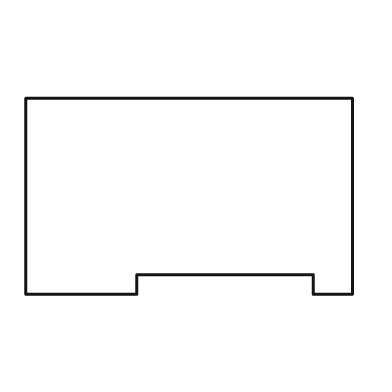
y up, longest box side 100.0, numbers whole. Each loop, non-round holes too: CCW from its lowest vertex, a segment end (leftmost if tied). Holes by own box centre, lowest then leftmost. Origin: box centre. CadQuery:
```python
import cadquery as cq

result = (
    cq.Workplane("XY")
    .moveTo(-50.0, -30.0)
    .lineTo(-16.0, -30.0)
    .lineTo(-16.0, -24.0)
    .lineTo(38.0, -24.0)
    .lineTo(38.0, -30.0)
    .lineTo(50.0, -30.0)
    .lineTo(50.0, 30.0)
    .lineTo(-50.0, 30.0)
    .close()
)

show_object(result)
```